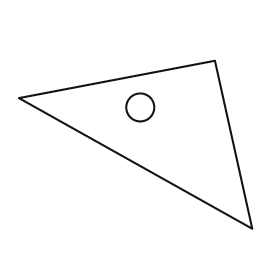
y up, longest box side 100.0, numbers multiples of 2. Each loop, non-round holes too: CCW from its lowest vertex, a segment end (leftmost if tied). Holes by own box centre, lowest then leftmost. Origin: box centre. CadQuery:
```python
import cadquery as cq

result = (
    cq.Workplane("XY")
    .moveTo(50.0, -36.0)
    .lineTo(34.0, 36.0)
    .lineTo(-50.0, 20.0)
    .close()
    .moveTo(2.0, 16.0)
    .circle(6.0)
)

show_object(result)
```